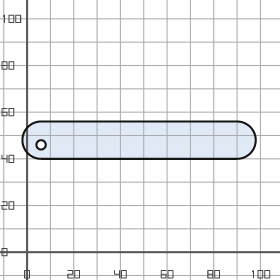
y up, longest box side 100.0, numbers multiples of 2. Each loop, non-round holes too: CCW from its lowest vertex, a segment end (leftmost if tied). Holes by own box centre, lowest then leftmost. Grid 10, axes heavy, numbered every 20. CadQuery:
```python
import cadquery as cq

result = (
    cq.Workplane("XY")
    .moveTo(6.0, 40.0)
    .lineTo(90.0, 40.0)
    .threePointArc((98.0, 48.0), (90.0, 56.0))
    .lineTo(6.0, 56.0)
    .threePointArc((-2.0, 48.0), (6.0, 40.0))
    .close()
    .moveTo(6.0, 46.0)
    .circle(2.0)
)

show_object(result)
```